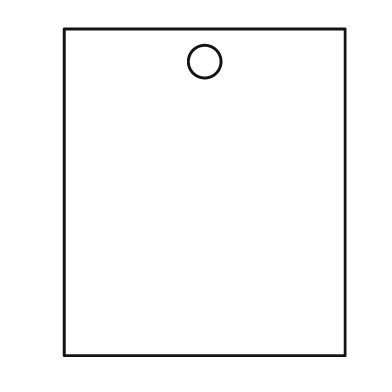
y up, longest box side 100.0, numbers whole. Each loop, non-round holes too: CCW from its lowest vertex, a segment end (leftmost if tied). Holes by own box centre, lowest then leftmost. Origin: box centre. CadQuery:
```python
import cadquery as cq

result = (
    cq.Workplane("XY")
    .moveTo(-43.0, -50.0)
    .lineTo(43.0, -50.0)
    .lineTo(43.0, 50.0)
    .lineTo(-43.0, 50.0)
    .close()
    .moveTo(0.0, 40.0)
    .circle(5.0)
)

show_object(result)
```